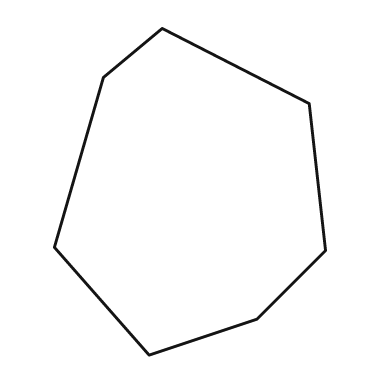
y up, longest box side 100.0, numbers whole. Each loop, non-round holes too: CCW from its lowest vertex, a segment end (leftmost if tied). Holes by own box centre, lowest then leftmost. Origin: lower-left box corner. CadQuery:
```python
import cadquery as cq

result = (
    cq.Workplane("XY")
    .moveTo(29.0, 0.0)
    .lineTo(62.0, 11.0)
    .lineTo(83.0, 32.0)
    .lineTo(78.0, 77.0)
    .lineTo(33.0, 100.0)
    .lineTo(15.0, 85.0)
    .lineTo(0.0, 33.0)
    .close()
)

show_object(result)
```